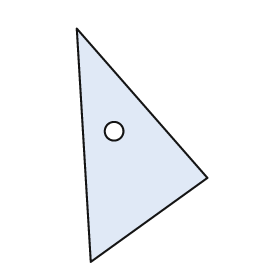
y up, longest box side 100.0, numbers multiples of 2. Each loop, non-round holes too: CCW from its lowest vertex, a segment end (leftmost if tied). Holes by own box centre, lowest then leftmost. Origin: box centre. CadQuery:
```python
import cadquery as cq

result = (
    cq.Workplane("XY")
    .moveTo(-22.0, -50.0)
    .lineTo(28.0, -14.0)
    .lineTo(-28.0, 50.0)
    .close()
    .moveTo(-12.0, 6.0)
    .circle(4.0)
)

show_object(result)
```